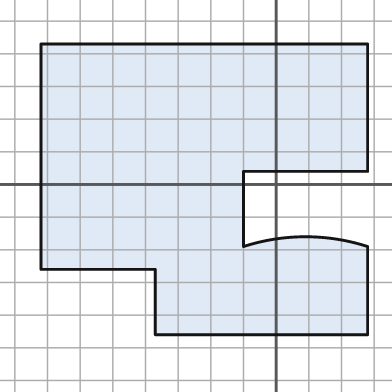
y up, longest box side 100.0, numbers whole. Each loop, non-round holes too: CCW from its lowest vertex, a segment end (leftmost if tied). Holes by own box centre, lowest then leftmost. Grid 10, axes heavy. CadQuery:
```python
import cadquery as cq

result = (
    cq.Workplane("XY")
    .moveTo(-37.0, -46.0)
    .lineTo(28.0, -46.0)
    .lineTo(28.0, -19.0)
    .threePointArc((9.0, -16.0), (-10.0, -19.0))
    .lineTo(-10.0, 4.0)
    .lineTo(28.0, 4.0)
    .lineTo(28.0, 43.0)
    .lineTo(-72.0, 43.0)
    .lineTo(-72.0, -26.0)
    .lineTo(-37.0, -26.0)
    .close()
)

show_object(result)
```